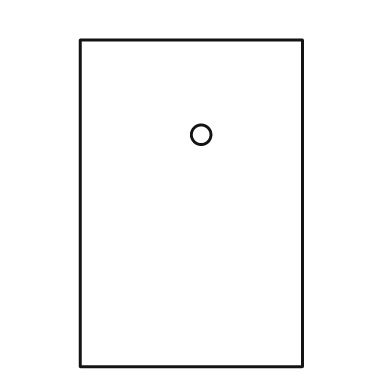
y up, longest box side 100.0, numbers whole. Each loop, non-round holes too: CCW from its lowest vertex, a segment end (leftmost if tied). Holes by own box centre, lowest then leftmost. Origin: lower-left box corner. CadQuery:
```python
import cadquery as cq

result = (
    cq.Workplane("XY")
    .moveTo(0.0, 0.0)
    .lineTo(68.0, 0.0)
    .lineTo(68.0, 100.0)
    .lineTo(0.0, 100.0)
    .close()
    .moveTo(37.0, 71.0)
    .circle(3.0)
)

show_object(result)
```